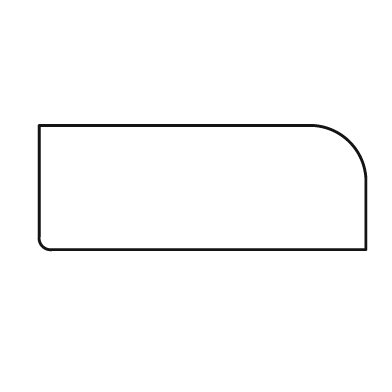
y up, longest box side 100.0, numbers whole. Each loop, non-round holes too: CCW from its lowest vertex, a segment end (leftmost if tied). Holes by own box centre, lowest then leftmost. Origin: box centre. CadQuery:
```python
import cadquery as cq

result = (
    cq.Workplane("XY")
    .moveTo(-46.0, -19.0)
    .lineTo(50.0, -19.0)
    .lineTo(50.0, 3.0)
    .threePointArc((45.0, 14.0), (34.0, 19.0))
    .lineTo(-50.0, 19.0)
    .lineTo(-50.0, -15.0)
    .threePointArc((-49.0, -18.0), (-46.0, -19.0))
    .close()
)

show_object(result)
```